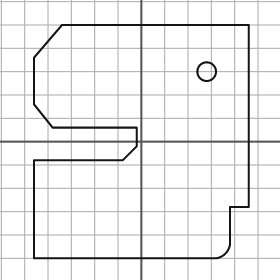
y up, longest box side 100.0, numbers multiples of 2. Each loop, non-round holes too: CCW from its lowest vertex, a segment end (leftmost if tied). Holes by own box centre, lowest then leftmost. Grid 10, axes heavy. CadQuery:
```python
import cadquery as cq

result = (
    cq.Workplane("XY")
    .moveTo(-46.0, -50.0)
    .lineTo(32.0, -50.0)
    .threePointArc((36.0, -48.0), (38.0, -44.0))
    .lineTo(38.0, -28.0)
    .lineTo(46.0, -28.0)
    .lineTo(46.0, 50.0)
    .lineTo(-34.0, 50.0)
    .lineTo(-46.0, 36.0)
    .lineTo(-46.0, 16.0)
    .lineTo(-38.0, 6.0)
    .lineTo(-2.0, 6.0)
    .lineTo(-2.0, -2.0)
    .lineTo(-8.0, -8.0)
    .lineTo(-46.0, -8.0)
    .close()
    .moveTo(28.0, 30.0)
    .circle(4.0)
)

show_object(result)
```